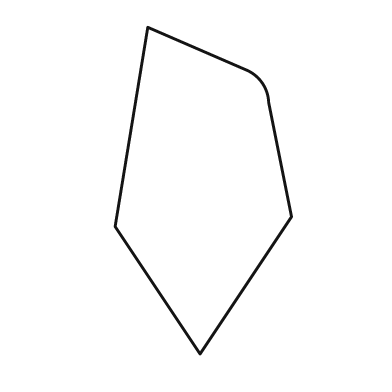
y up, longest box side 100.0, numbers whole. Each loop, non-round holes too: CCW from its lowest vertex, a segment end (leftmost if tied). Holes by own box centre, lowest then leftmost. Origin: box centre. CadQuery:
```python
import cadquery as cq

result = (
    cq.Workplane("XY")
    .moveTo(-1.0, -50.0)
    .lineTo(27.0, -8.0)
    .lineTo(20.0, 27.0)
    .threePointArc((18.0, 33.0), (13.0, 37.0))
    .lineTo(-17.0, 50.0)
    .lineTo(-27.0, -11.0)
    .close()
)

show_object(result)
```